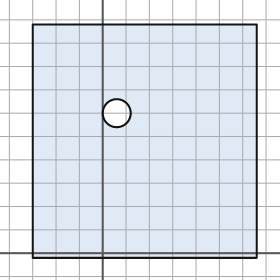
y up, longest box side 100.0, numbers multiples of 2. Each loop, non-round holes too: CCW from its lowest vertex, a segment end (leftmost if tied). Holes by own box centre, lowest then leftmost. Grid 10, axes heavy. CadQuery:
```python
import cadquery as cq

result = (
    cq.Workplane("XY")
    .moveTo(-30.0, -2.0)
    .lineTo(66.0, -2.0)
    .lineTo(66.0, 98.0)
    .lineTo(-30.0, 98.0)
    .close()
    .moveTo(6.0, 60.0)
    .circle(6.0)
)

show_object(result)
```